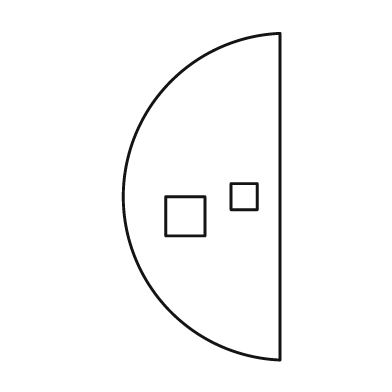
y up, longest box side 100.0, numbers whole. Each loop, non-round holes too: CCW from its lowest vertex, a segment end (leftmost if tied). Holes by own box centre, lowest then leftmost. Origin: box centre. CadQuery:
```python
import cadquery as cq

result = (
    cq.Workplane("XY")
    .moveTo(24.0, -50.0)
    .lineTo(24.0, 50.0)
    .threePointArc((-24.0, 0.0), (24.0, -50.0))
    .close()
    .moveTo(-11.0, -12.0)
    .lineTo(1.0, -12.0)
    .lineTo(1.0, 0.0)
    .lineTo(-11.0, 0.0)
    .close()
    .moveTo(9.0, -4.0)
    .lineTo(17.0, -4.0)
    .lineTo(17.0, 4.0)
    .lineTo(9.0, 4.0)
    .close()
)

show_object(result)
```